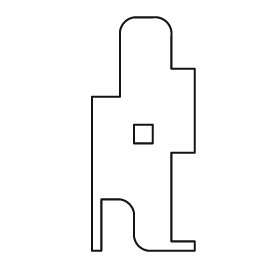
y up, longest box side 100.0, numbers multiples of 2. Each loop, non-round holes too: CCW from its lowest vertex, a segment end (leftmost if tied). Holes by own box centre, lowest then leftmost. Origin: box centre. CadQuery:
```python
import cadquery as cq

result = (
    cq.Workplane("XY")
    .moveTo(-22.0, -50.0)
    .lineTo(-18.0, -50.0)
    .lineTo(-18.0, -28.0)
    .lineTo(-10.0, -28.0)
    .threePointArc((-6.0, -30.0), (-4.0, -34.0))
    .lineTo(-4.0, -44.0)
    .threePointArc((-2.0, -48.0), (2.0, -50.0))
    .lineTo(22.0, -50.0)
    .lineTo(22.0, -46.0)
    .lineTo(12.0, -46.0)
    .lineTo(12.0, -8.0)
    .lineTo(22.0, -8.0)
    .lineTo(22.0, 28.0)
    .lineTo(12.0, 28.0)
    .lineTo(12.0, 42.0)
    .threePointArc((10.0, 48.0), (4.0, 50.0))
    .lineTo(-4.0, 50.0)
    .threePointArc((-8.0, 48.0), (-10.0, 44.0))
    .lineTo(-10.0, 16.0)
    .lineTo(-22.0, 16.0)
    .close()
    .moveTo(-4.0, -4.0)
    .lineTo(4.0, -4.0)
    .lineTo(4.0, 4.0)
    .lineTo(-4.0, 4.0)
    .close()
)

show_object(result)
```